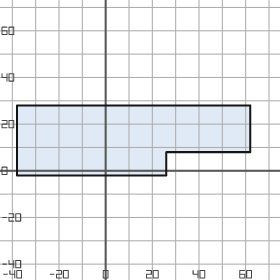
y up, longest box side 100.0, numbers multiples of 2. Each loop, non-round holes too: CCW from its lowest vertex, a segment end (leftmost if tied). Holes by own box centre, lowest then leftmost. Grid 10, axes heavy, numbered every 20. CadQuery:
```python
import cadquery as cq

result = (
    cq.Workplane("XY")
    .moveTo(-38.0, -2.0)
    .lineTo(26.0, -2.0)
    .lineTo(26.0, 8.0)
    .lineTo(62.0, 8.0)
    .lineTo(62.0, 28.0)
    .lineTo(-38.0, 28.0)
    .close()
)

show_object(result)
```